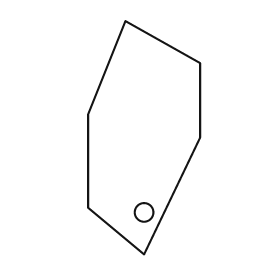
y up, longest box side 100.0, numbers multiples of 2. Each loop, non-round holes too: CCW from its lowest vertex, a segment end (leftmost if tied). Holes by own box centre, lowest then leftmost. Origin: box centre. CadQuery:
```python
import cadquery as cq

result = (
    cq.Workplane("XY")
    .moveTo(0.0, -50.0)
    .lineTo(24.0, 0.0)
    .lineTo(24.0, 32.0)
    .lineTo(-8.0, 50.0)
    .lineTo(-24.0, 10.0)
    .lineTo(-24.0, -30.0)
    .close()
    .moveTo(0.0, -32.0)
    .circle(4.0)
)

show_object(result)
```